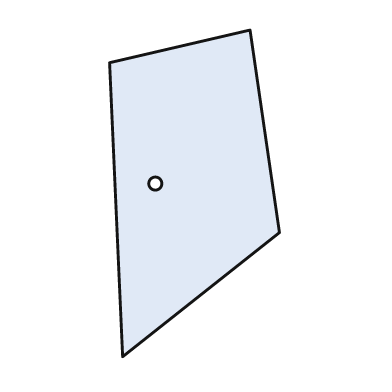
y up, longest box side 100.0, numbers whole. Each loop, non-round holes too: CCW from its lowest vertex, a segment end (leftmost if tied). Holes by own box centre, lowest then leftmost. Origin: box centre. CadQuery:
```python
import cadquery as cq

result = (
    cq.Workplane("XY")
    .moveTo(-22.0, -50.0)
    .lineTo(26.0, -12.0)
    .lineTo(17.0, 50.0)
    .lineTo(-26.0, 40.0)
    .close()
    .moveTo(-12.0, 3.0)
    .circle(2.0)
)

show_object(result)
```